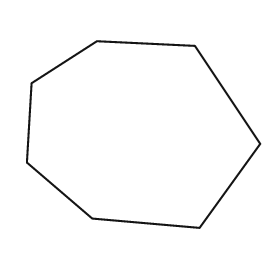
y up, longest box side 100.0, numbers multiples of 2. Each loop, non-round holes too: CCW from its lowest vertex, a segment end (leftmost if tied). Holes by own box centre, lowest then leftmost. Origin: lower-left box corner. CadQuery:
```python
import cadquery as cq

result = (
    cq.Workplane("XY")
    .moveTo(74.0, 0.0)
    .lineTo(100.0, 36.0)
    .lineTo(72.0, 78.0)
    .lineTo(30.0, 80.0)
    .lineTo(2.0, 62.0)
    .lineTo(0.0, 28.0)
    .lineTo(28.0, 4.0)
    .close()
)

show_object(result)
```